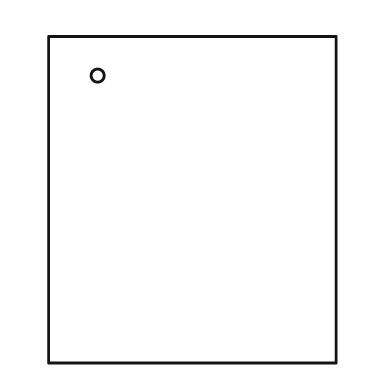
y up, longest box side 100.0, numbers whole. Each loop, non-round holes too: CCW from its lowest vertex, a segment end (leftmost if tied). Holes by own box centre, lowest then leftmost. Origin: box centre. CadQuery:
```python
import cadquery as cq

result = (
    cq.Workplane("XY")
    .moveTo(-44.0, -50.0)
    .lineTo(44.0, -50.0)
    .lineTo(44.0, 50.0)
    .lineTo(-44.0, 50.0)
    .close()
    .moveTo(-29.0, 38.0)
    .circle(2.0)
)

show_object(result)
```